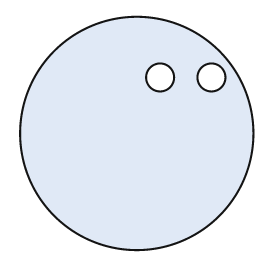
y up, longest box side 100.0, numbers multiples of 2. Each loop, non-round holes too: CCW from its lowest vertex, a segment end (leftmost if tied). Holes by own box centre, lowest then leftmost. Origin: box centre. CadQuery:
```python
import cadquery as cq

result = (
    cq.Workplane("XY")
    .moveTo(0.0, 0.0)
    .circle(50.0)
    .moveTo(10.0, 24.0)
    .circle(6.0)
    .moveTo(32.0, 24.0)
    .circle(6.0)
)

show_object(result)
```